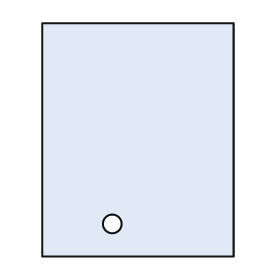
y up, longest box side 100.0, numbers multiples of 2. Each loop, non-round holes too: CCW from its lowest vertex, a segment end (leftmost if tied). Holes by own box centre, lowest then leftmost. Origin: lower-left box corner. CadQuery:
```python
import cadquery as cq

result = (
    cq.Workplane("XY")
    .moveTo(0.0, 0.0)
    .lineTo(82.0, 0.0)
    .lineTo(82.0, 100.0)
    .lineTo(0.0, 100.0)
    .close()
    .moveTo(30.0, 14.0)
    .circle(4.0)
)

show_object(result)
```